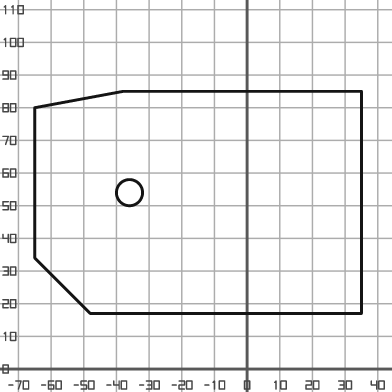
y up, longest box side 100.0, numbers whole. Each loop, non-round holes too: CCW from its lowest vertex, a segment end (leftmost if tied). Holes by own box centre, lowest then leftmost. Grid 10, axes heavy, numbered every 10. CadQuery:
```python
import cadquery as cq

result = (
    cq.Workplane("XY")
    .moveTo(-48.0, 17.0)
    .lineTo(35.0, 17.0)
    .lineTo(35.0, 85.0)
    .lineTo(-38.0, 85.0)
    .lineTo(-65.0, 80.0)
    .lineTo(-65.0, 34.0)
    .close()
    .moveTo(-36.0, 54.0)
    .circle(4.0)
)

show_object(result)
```